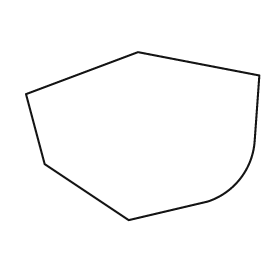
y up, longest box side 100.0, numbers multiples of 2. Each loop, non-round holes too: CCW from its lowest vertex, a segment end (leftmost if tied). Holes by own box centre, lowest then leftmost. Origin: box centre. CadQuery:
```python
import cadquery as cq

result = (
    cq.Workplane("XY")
    .moveTo(-6.0, -36.0)
    .lineTo(28.0, -28.0)
    .threePointArc((42.0, -18.0), (48.0, -2.0))
    .lineTo(50.0, 26.0)
    .lineTo(-2.0, 36.0)
    .lineTo(-50.0, 18.0)
    .lineTo(-42.0, -12.0)
    .close()
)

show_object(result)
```